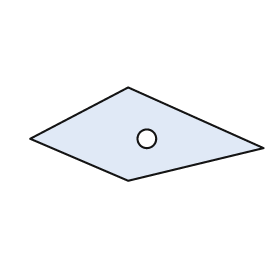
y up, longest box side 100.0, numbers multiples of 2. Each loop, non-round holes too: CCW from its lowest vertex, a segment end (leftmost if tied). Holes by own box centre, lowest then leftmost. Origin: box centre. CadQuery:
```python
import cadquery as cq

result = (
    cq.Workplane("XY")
    .moveTo(-8.0, -20.0)
    .lineTo(50.0, -6.0)
    .lineTo(-8.0, 20.0)
    .lineTo(-50.0, -2.0)
    .close()
    .moveTo(0.0, -2.0)
    .circle(4.0)
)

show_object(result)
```